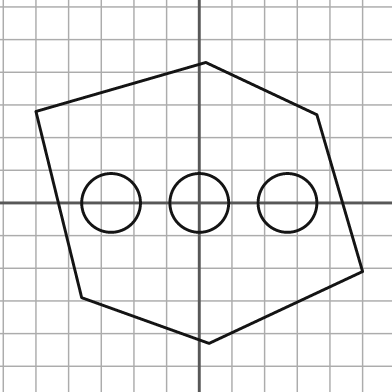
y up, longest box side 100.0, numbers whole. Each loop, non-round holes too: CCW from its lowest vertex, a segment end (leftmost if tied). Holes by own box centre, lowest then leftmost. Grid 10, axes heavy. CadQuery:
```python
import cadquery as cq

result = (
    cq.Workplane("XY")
    .moveTo(3.0, -43.0)
    .lineTo(50.0, -21.0)
    .lineTo(36.0, 27.0)
    .lineTo(2.0, 43.0)
    .lineTo(-50.0, 28.0)
    .lineTo(-36.0, -29.0)
    .close()
    .moveTo(-27.0, 0.0)
    .circle(9.0)
    .moveTo(0.0, 0.0)
    .circle(9.0)
    .moveTo(27.0, 0.0)
    .circle(9.0)
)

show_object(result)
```